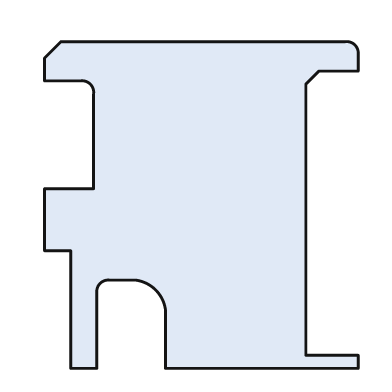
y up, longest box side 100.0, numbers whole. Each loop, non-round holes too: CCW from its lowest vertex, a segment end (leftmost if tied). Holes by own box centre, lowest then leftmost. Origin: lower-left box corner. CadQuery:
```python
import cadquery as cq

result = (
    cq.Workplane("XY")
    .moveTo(8.0, 0.0)
    .lineTo(16.0, 0.0)
    .lineTo(16.0, 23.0)
    .threePointArc((17.0, 26.0), (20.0, 27.0))
    .lineTo(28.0, 27.0)
    .threePointArc((34.0, 24.0), (37.0, 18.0))
    .lineTo(37.0, 0.0)
    .lineTo(96.0, 0.0)
    .lineTo(96.0, 4.0)
    .lineTo(80.0, 4.0)
    .lineTo(80.0, 87.0)
    .lineTo(84.0, 91.0)
    .lineTo(96.0, 91.0)
    .lineTo(96.0, 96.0)
    .threePointArc((95.0, 99.0), (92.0, 100.0))
    .lineTo(5.0, 100.0)
    .lineTo(0.0, 95.0)
    .lineTo(0.0, 88.0)
    .lineTo(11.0, 88.0)
    .threePointArc((14.0, 87.0), (15.0, 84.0))
    .lineTo(15.0, 55.0)
    .lineTo(0.0, 55.0)
    .lineTo(0.0, 36.0)
    .lineTo(8.0, 36.0)
    .close()
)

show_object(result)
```